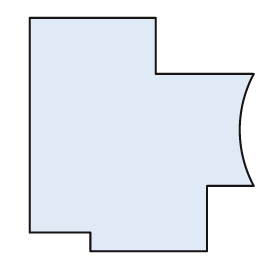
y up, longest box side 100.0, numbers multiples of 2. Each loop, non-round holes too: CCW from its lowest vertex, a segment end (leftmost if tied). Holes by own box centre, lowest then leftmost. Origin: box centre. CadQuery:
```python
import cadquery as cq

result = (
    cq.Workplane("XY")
    .moveTo(-22.0, -50.0)
    .lineTo(28.0, -50.0)
    .lineTo(28.0, -22.0)
    .lineTo(48.0, -22.0)
    .threePointArc((42.0, 2.0), (48.0, 26.0))
    .lineTo(6.0, 26.0)
    .lineTo(6.0, 50.0)
    .lineTo(-48.0, 50.0)
    .lineTo(-48.0, -42.0)
    .lineTo(-22.0, -42.0)
    .close()
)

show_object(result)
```